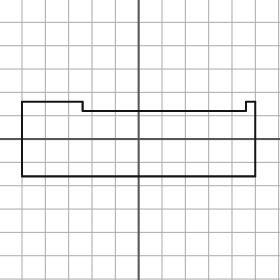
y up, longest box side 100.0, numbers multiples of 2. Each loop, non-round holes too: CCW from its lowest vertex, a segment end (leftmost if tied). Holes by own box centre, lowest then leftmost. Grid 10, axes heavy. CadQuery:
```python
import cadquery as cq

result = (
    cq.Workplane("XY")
    .moveTo(-50.0, -16.0)
    .lineTo(50.0, -16.0)
    .lineTo(50.0, 16.0)
    .lineTo(46.0, 16.0)
    .lineTo(46.0, 12.0)
    .lineTo(-24.0, 12.0)
    .lineTo(-24.0, 16.0)
    .lineTo(-50.0, 16.0)
    .close()
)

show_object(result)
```